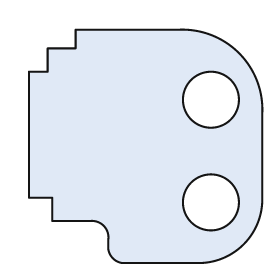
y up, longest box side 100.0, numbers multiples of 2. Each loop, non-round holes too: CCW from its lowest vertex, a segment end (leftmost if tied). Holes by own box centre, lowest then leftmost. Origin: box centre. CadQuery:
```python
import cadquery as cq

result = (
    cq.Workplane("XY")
    .moveTo(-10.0, -50.0)
    .lineTo(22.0, -50.0)
    .threePointArc((42.0, -42.0), (50.0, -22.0))
    .lineTo(50.0, 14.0)
    .threePointArc((40.0, 40.0), (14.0, 50.0))
    .lineTo(-30.0, 50.0)
    .lineTo(-30.0, 42.0)
    .lineTo(-42.0, 42.0)
    .lineTo(-42.0, 32.0)
    .lineTo(-50.0, 32.0)
    .lineTo(-50.0, -22.0)
    .lineTo(-40.0, -22.0)
    .lineTo(-40.0, -32.0)
    .lineTo(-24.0, -32.0)
    .threePointArc((-18.0, -34.0), (-16.0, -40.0))
    .lineTo(-16.0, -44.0)
    .threePointArc((-14.0, -48.0), (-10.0, -50.0))
    .close()
    .moveTo(28.0, -24.0)
    .circle(12.0)
    .moveTo(28.0, 20.0)
    .circle(12.0)
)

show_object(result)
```